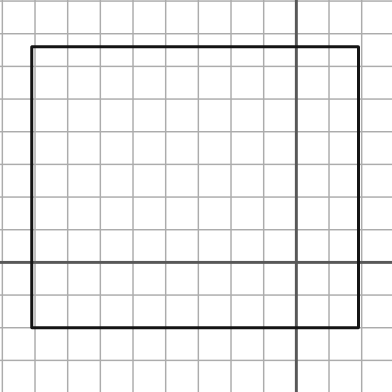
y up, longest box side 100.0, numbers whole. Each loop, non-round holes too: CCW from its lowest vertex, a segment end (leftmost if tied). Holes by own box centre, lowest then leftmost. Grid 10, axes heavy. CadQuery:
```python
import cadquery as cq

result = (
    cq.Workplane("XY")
    .moveTo(-81.0, -20.0)
    .lineTo(19.0, -20.0)
    .lineTo(19.0, 66.0)
    .lineTo(-81.0, 66.0)
    .close()
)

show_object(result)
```